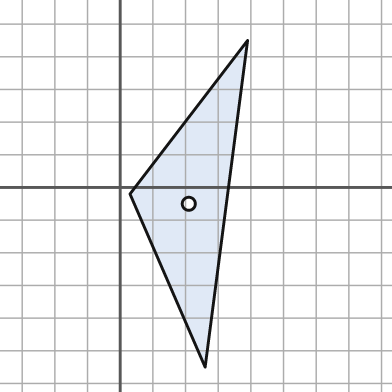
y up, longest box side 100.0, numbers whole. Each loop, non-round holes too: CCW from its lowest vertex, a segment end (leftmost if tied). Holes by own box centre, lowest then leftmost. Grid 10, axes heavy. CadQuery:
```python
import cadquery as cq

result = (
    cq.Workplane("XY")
    .moveTo(26.0, -55.0)
    .lineTo(39.0, 45.0)
    .lineTo(3.0, -2.0)
    .close()
    .moveTo(21.0, -5.0)
    .circle(2.0)
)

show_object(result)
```